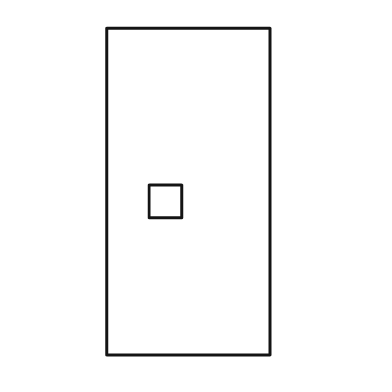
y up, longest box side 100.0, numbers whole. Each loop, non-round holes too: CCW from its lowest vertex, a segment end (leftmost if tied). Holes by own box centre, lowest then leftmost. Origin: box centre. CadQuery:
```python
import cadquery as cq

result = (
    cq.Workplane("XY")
    .moveTo(-25.0, -50.0)
    .lineTo(25.0, -50.0)
    .lineTo(25.0, 50.0)
    .lineTo(-25.0, 50.0)
    .close()
    .moveTo(-12.0, -8.0)
    .lineTo(-2.0, -8.0)
    .lineTo(-2.0, 2.0)
    .lineTo(-12.0, 2.0)
    .close()
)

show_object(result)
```